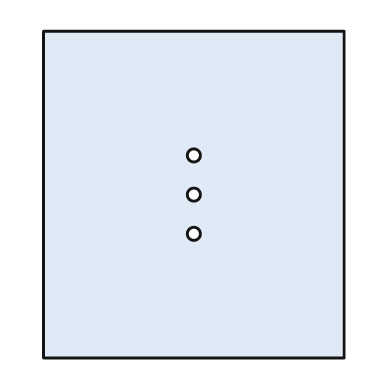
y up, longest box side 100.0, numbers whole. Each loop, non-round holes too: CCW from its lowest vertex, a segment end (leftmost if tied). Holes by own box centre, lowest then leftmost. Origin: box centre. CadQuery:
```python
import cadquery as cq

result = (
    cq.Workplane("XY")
    .moveTo(-46.0, -50.0)
    .lineTo(46.0, -50.0)
    .lineTo(46.0, 50.0)
    .lineTo(-46.0, 50.0)
    .close()
    .moveTo(0.0, -12.0)
    .circle(2.0)
    .moveTo(0.0, 0.0)
    .circle(2.0)
    .moveTo(0.0, 12.0)
    .circle(2.0)
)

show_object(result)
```